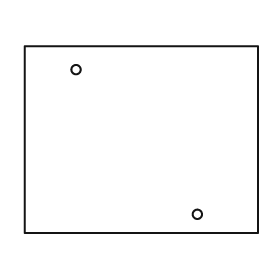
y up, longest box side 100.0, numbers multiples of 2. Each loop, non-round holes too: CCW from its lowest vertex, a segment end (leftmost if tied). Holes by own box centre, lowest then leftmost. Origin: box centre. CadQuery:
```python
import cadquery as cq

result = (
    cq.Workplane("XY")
    .moveTo(-50.0, -40.0)
    .lineTo(50.0, -40.0)
    .lineTo(50.0, 40.0)
    .lineTo(-50.0, 40.0)
    .close()
    .moveTo(24.0, -32.0)
    .circle(2.0)
    .moveTo(-28.0, 30.0)
    .circle(2.0)
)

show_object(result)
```